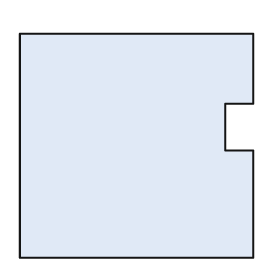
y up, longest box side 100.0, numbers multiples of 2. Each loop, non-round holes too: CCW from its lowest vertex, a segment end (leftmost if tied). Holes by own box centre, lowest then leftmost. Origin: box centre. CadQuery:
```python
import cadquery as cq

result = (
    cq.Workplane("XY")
    .moveTo(-50.0, -48.0)
    .lineTo(50.0, -48.0)
    .lineTo(50.0, -2.0)
    .lineTo(38.0, -2.0)
    .lineTo(38.0, 18.0)
    .lineTo(50.0, 18.0)
    .lineTo(50.0, 48.0)
    .lineTo(-50.0, 48.0)
    .close()
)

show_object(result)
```